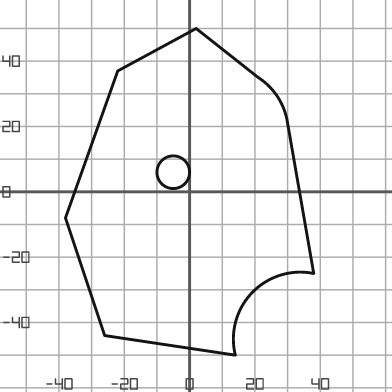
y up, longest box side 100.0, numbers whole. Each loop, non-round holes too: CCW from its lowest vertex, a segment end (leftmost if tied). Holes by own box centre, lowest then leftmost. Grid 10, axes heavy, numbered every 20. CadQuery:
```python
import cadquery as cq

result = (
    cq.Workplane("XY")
    .moveTo(14.0, -50.0)
    .threePointArc((19.0, -31.0), (38.0, -25.0))
    .lineTo(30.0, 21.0)
    .threePointArc((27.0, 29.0), (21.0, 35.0))
    .lineTo(2.0, 50.0)
    .lineTo(-22.0, 37.0)
    .lineTo(-38.0, -8.0)
    .lineTo(-26.0, -44.0)
    .close()
    .moveTo(-5.0, 6.0)
    .circle(5.0)
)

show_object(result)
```